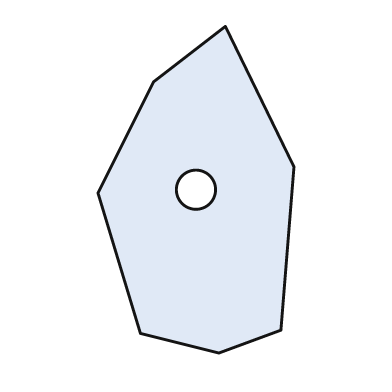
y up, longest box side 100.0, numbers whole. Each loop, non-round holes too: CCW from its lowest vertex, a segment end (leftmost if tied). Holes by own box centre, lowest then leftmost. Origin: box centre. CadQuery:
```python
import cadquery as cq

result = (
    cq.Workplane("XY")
    .moveTo(7.0, -50.0)
    .lineTo(26.0, -43.0)
    .lineTo(30.0, 7.0)
    .lineTo(9.0, 50.0)
    .lineTo(-13.0, 33.0)
    .lineTo(-30.0, -1.0)
    .lineTo(-17.0, -44.0)
    .close()
    .moveTo(0.0, 0.0)
    .circle(6.0)
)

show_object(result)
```